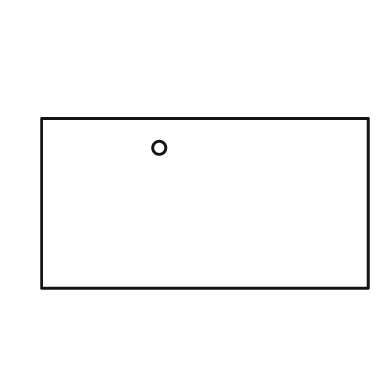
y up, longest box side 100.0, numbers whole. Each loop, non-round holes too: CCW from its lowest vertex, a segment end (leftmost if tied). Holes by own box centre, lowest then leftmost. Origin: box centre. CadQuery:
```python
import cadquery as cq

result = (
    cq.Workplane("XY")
    .moveTo(-50.0, -26.0)
    .lineTo(50.0, -26.0)
    .lineTo(50.0, 26.0)
    .lineTo(-50.0, 26.0)
    .close()
    .moveTo(-14.0, 17.0)
    .circle(2.0)
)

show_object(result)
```